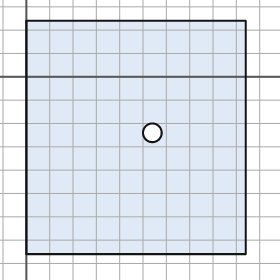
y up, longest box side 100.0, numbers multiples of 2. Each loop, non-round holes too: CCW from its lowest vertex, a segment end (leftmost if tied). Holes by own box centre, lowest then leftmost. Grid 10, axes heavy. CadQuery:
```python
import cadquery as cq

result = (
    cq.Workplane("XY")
    .moveTo(0.0, -76.0)
    .lineTo(94.0, -76.0)
    .lineTo(94.0, 24.0)
    .lineTo(0.0, 24.0)
    .close()
    .moveTo(54.0, -24.0)
    .circle(4.0)
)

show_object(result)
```